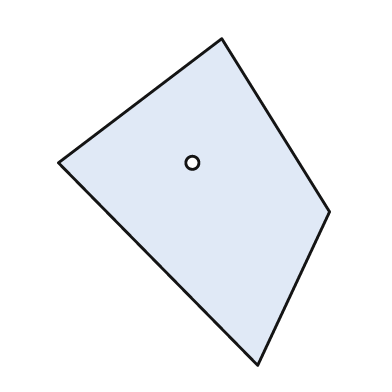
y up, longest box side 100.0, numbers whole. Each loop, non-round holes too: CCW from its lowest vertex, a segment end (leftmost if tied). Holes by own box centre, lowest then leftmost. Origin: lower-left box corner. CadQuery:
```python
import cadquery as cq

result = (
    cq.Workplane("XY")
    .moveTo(61.0, 0.0)
    .lineTo(83.0, 47.0)
    .lineTo(50.0, 100.0)
    .lineTo(0.0, 62.0)
    .close()
    .moveTo(41.0, 62.0)
    .circle(2.0)
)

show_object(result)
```